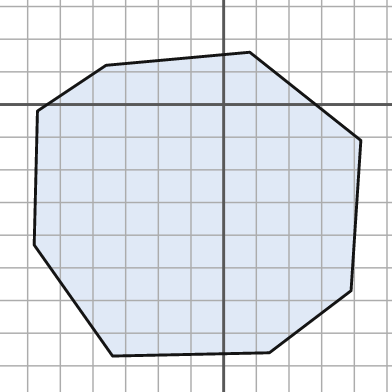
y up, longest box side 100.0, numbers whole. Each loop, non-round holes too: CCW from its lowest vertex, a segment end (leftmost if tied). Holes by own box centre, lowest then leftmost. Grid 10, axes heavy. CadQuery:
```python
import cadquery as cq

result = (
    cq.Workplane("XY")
    .moveTo(-34.0, -77.0)
    .lineTo(14.0, -76.0)
    .lineTo(39.0, -57.0)
    .lineTo(42.0, -11.0)
    .lineTo(8.0, 16.0)
    .lineTo(-36.0, 12.0)
    .lineTo(-57.0, -2.0)
    .lineTo(-58.0, -43.0)
    .close()
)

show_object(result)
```